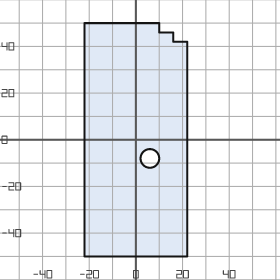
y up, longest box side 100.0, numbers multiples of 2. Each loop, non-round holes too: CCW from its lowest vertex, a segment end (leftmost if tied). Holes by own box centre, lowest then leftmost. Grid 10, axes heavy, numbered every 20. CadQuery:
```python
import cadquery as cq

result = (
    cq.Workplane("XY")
    .moveTo(-22.0, -50.0)
    .lineTo(22.0, -50.0)
    .lineTo(22.0, 42.0)
    .lineTo(16.0, 42.0)
    .lineTo(16.0, 46.0)
    .lineTo(10.0, 46.0)
    .lineTo(10.0, 50.0)
    .lineTo(-22.0, 50.0)
    .close()
    .moveTo(6.0, -8.0)
    .circle(4.0)
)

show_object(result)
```